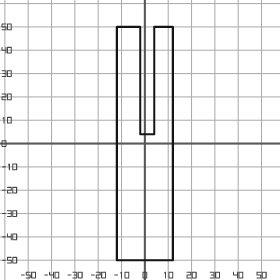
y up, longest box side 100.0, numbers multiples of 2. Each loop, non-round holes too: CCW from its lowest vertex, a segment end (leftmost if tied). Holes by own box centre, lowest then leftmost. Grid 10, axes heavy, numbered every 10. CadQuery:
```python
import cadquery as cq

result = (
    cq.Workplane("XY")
    .moveTo(-12.0, -50.0)
    .lineTo(12.0, -50.0)
    .lineTo(12.0, 50.0)
    .lineTo(4.0, 50.0)
    .lineTo(4.0, 4.0)
    .lineTo(-2.0, 4.0)
    .lineTo(-2.0, 50.0)
    .lineTo(-12.0, 50.0)
    .close()
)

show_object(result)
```